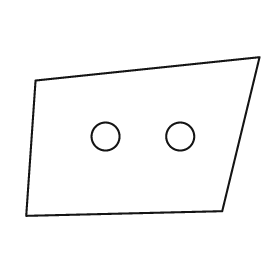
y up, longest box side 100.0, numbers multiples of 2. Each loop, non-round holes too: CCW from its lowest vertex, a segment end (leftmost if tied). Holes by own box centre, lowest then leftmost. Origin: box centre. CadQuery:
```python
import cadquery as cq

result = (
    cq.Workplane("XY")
    .moveTo(-50.0, -34.0)
    .lineTo(34.0, -32.0)
    .lineTo(50.0, 34.0)
    .lineTo(-46.0, 24.0)
    .close()
    .moveTo(-16.0, 0.0)
    .circle(6.0)
    .moveTo(16.0, 0.0)
    .circle(6.0)
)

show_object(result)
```